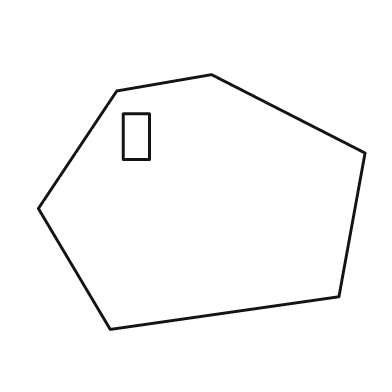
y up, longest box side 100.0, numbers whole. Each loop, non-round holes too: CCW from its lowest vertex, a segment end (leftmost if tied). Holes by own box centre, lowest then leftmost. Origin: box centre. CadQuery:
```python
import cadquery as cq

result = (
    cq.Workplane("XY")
    .moveTo(-28.0, -39.0)
    .lineTo(42.0, -29.0)
    .lineTo(50.0, 15.0)
    .lineTo(3.0, 39.0)
    .lineTo(-26.0, 34.0)
    .lineTo(-50.0, -2.0)
    .close()
    .moveTo(-24.0, 13.0)
    .lineTo(-16.0, 13.0)
    .lineTo(-16.0, 27.0)
    .lineTo(-24.0, 27.0)
    .close()
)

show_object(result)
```